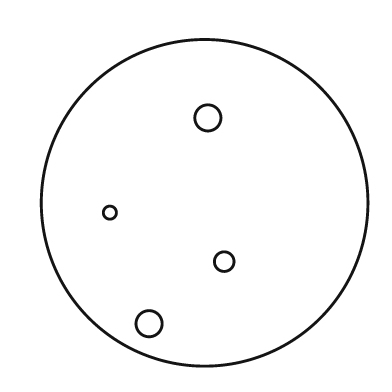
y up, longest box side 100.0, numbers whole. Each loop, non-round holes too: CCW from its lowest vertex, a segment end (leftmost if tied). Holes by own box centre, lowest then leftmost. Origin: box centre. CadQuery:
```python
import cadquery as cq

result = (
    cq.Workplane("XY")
    .moveTo(0.0, 0.0)
    .circle(50.0)
    .moveTo(-17.0, -37.0)
    .circle(4.0)
    .moveTo(6.0, -18.0)
    .circle(3.0)
    .moveTo(-29.0, -3.0)
    .circle(2.0)
    .moveTo(1.0, 26.0)
    .circle(4.0)
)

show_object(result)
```